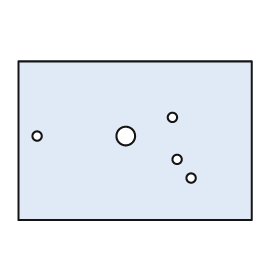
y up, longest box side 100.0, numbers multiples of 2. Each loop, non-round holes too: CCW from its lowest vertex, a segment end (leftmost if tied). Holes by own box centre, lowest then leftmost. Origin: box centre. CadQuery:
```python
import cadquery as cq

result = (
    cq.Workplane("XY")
    .moveTo(-50.0, -34.0)
    .lineTo(50.0, -34.0)
    .lineTo(50.0, 34.0)
    .lineTo(-50.0, 34.0)
    .close()
    .moveTo(24.0, -16.0)
    .circle(2.0)
    .moveTo(18.0, -8.0)
    .circle(2.0)
    .moveTo(-42.0, 2.0)
    .circle(2.0)
    .moveTo(-4.0, 2.0)
    .circle(4.0)
    .moveTo(16.0, 10.0)
    .circle(2.0)
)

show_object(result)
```